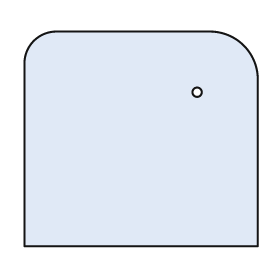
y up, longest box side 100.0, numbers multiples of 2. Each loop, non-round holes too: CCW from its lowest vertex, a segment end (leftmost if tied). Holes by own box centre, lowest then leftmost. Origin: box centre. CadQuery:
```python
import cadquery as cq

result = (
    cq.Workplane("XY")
    .moveTo(-50.0, -46.0)
    .lineTo(50.0, -46.0)
    .lineTo(50.0, 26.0)
    .threePointArc((44.0, 40.0), (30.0, 46.0))
    .lineTo(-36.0, 46.0)
    .threePointArc((-46.0, 42.0), (-50.0, 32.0))
    .close()
    .moveTo(24.0, 20.0)
    .circle(2.0)
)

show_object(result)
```